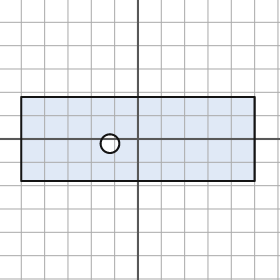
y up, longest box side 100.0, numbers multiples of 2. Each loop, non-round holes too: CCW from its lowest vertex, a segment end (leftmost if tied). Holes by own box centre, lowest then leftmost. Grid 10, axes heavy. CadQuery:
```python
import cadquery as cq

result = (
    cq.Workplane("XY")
    .moveTo(-50.0, -18.0)
    .lineTo(50.0, -18.0)
    .lineTo(50.0, 18.0)
    .lineTo(-50.0, 18.0)
    .close()
    .moveTo(-12.0, -2.0)
    .circle(4.0)
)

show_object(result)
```